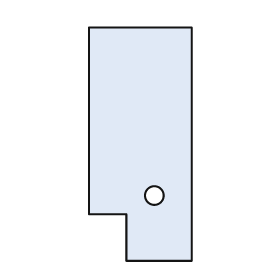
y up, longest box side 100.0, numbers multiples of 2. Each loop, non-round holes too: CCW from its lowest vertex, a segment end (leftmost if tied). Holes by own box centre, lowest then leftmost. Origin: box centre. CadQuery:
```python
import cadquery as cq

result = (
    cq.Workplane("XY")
    .moveTo(-6.0, -50.0)
    .lineTo(22.0, -50.0)
    .lineTo(22.0, 50.0)
    .lineTo(-22.0, 50.0)
    .lineTo(-22.0, -30.0)
    .lineTo(-6.0, -30.0)
    .close()
    .moveTo(6.0, -22.0)
    .circle(4.0)
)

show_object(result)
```